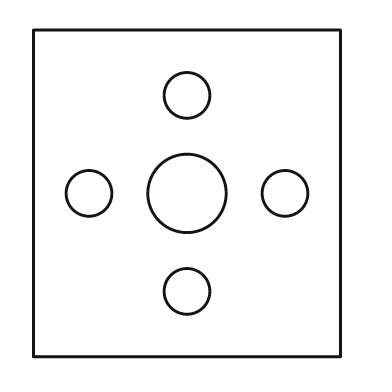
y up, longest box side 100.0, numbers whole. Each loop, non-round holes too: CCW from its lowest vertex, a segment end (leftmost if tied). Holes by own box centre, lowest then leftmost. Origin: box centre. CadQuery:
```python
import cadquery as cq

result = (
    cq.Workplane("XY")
    .moveTo(-47.0, -50.0)
    .lineTo(47.0, -50.0)
    .lineTo(47.0, 50.0)
    .lineTo(-47.0, 50.0)
    .close()
    .moveTo(0.0, -30.0)
    .circle(7.0)
    .moveTo(-30.0, 0.0)
    .circle(7.0)
    .moveTo(0.0, 0.0)
    .circle(12.0)
    .moveTo(30.0, 0.0)
    .circle(7.0)
    .moveTo(0.0, 30.0)
    .circle(7.0)
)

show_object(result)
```